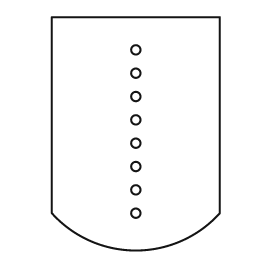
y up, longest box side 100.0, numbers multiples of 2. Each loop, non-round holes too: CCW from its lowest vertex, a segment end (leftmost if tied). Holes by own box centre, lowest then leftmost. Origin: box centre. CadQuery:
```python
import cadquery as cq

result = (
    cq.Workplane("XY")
    .moveTo(-36.0, -34.0)
    .threePointArc((0.0, -50.0), (36.0, -34.0))
    .lineTo(36.0, 50.0)
    .lineTo(-36.0, 50.0)
    .close()
    .moveTo(0.0, -34.0)
    .circle(2.0)
    .moveTo(0.0, -24.0)
    .circle(2.0)
    .moveTo(0.0, -14.0)
    .circle(2.0)
    .moveTo(0.0, -4.0)
    .circle(2.0)
    .moveTo(0.0, 6.0)
    .circle(2.0)
    .moveTo(0.0, 16.0)
    .circle(2.0)
    .moveTo(0.0, 26.0)
    .circle(2.0)
    .moveTo(0.0, 36.0)
    .circle(2.0)
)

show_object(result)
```